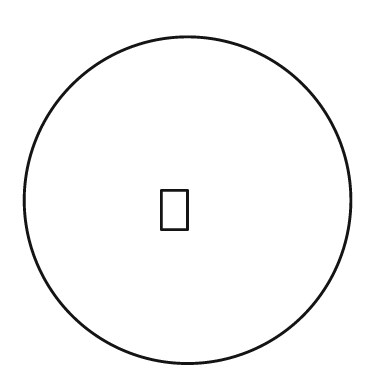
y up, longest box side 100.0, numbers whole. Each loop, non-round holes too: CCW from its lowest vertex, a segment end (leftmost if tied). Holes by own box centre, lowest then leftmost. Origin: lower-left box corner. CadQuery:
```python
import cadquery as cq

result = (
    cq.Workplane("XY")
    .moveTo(50.0, 50.0)
    .circle(50.0)
    .moveTo(42.0, 41.0)
    .lineTo(50.0, 41.0)
    .lineTo(50.0, 53.0)
    .lineTo(42.0, 53.0)
    .close()
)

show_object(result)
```